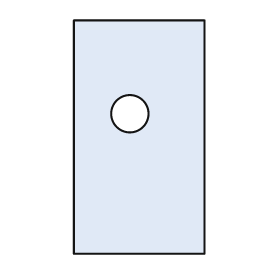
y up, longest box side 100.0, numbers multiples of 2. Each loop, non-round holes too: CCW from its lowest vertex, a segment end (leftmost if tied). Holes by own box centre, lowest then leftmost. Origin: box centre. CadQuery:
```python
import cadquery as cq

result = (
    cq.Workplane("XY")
    .moveTo(-28.0, -50.0)
    .lineTo(28.0, -50.0)
    .lineTo(28.0, 50.0)
    .lineTo(-28.0, 50.0)
    .close()
    .moveTo(-4.0, 10.0)
    .circle(8.0)
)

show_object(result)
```